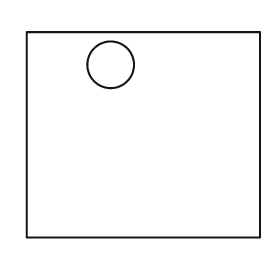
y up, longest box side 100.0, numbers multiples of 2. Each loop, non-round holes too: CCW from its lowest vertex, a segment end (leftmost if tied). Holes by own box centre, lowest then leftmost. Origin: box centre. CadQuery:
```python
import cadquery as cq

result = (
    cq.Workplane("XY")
    .moveTo(-50.0, -44.0)
    .lineTo(50.0, -44.0)
    .lineTo(50.0, 44.0)
    .lineTo(-50.0, 44.0)
    .close()
    .moveTo(-14.0, 30.0)
    .circle(10.0)
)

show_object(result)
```